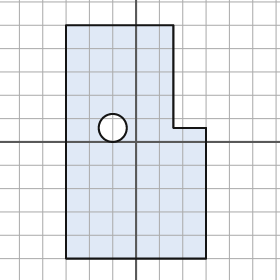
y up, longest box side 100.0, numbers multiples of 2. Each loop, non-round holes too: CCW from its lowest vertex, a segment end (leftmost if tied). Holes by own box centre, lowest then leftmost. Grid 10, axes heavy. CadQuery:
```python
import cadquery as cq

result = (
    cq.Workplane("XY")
    .moveTo(-30.0, -50.0)
    .lineTo(30.0, -50.0)
    .lineTo(30.0, 6.0)
    .lineTo(16.0, 6.0)
    .lineTo(16.0, 50.0)
    .lineTo(-30.0, 50.0)
    .close()
    .moveTo(-10.0, 6.0)
    .circle(6.0)
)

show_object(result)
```